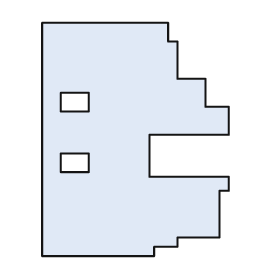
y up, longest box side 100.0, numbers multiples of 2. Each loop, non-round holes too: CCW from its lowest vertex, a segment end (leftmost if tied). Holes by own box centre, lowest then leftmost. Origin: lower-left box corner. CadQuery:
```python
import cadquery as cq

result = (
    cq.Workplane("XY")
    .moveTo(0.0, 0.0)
    .lineTo(48.0, 0.0)
    .lineTo(48.0, 4.0)
    .lineTo(58.0, 4.0)
    .lineTo(58.0, 8.0)
    .lineTo(76.0, 8.0)
    .lineTo(76.0, 28.0)
    .lineTo(80.0, 28.0)
    .lineTo(80.0, 34.0)
    .lineTo(46.0, 34.0)
    .lineTo(46.0, 52.0)
    .lineTo(80.0, 52.0)
    .lineTo(80.0, 64.0)
    .lineTo(70.0, 64.0)
    .lineTo(70.0, 76.0)
    .lineTo(58.0, 76.0)
    .lineTo(58.0, 92.0)
    .lineTo(54.0, 92.0)
    .lineTo(54.0, 100.0)
    .lineTo(0.0, 100.0)
    .close()
    .moveTo(8.0, 36.0)
    .lineTo(20.0, 36.0)
    .lineTo(20.0, 44.0)
    .lineTo(8.0, 44.0)
    .close()
    .moveTo(8.0, 62.0)
    .lineTo(20.0, 62.0)
    .lineTo(20.0, 70.0)
    .lineTo(8.0, 70.0)
    .close()
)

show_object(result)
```